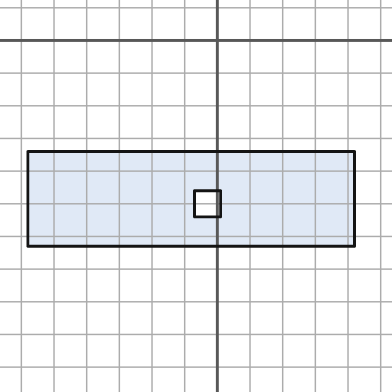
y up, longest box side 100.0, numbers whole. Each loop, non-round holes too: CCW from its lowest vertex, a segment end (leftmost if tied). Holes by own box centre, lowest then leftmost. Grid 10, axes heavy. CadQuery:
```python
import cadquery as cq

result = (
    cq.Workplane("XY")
    .moveTo(-58.0, -63.0)
    .lineTo(42.0, -63.0)
    .lineTo(42.0, -34.0)
    .lineTo(-58.0, -34.0)
    .close()
    .moveTo(-7.0, -54.0)
    .lineTo(1.0, -54.0)
    .lineTo(1.0, -46.0)
    .lineTo(-7.0, -46.0)
    .close()
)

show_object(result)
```